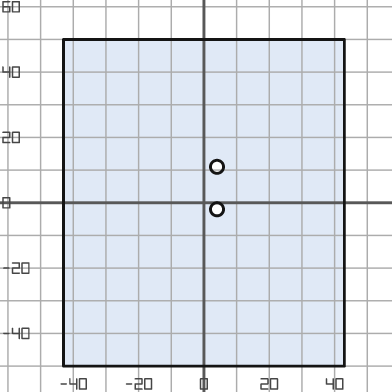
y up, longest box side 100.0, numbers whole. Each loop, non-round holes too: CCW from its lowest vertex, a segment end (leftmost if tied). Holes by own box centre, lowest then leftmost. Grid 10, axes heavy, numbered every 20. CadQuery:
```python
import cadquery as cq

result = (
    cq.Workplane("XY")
    .moveTo(-43.0, -50.0)
    .lineTo(43.0, -50.0)
    .lineTo(43.0, 50.0)
    .lineTo(-43.0, 50.0)
    .close()
    .moveTo(4.0, -2.0)
    .circle(2.0)
    .moveTo(4.0, 11.0)
    .circle(2.0)
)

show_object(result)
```